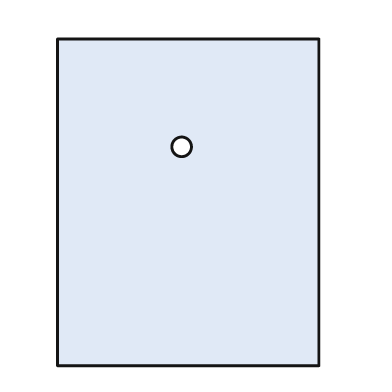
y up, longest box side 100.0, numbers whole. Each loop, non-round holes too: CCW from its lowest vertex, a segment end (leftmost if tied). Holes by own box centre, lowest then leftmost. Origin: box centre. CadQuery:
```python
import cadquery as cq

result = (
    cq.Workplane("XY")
    .moveTo(-40.0, -50.0)
    .lineTo(40.0, -50.0)
    .lineTo(40.0, 50.0)
    .lineTo(-40.0, 50.0)
    .close()
    .moveTo(-2.0, 17.0)
    .circle(3.0)
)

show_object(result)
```